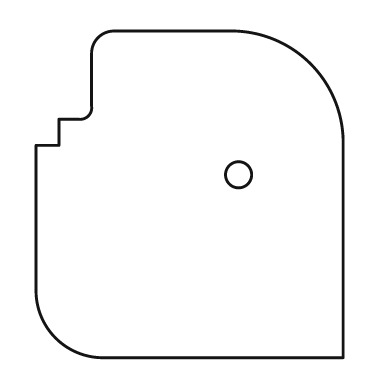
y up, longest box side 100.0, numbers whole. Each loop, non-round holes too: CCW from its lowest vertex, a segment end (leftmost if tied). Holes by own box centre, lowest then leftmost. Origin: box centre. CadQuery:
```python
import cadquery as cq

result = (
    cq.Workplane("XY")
    .moveTo(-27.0, -50.0)
    .lineTo(47.0, -50.0)
    .lineTo(47.0, 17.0)
    .threePointArc((37.0, 40.0), (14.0, 50.0))
    .lineTo(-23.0, 50.0)
    .threePointArc((-28.0, 48.0), (-30.0, 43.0))
    .lineTo(-30.0, 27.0)
    .threePointArc((-31.0, 24.0), (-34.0, 23.0))
    .lineTo(-40.0, 23.0)
    .lineTo(-40.0, 15.0)
    .lineTo(-47.0, 15.0)
    .lineTo(-47.0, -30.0)
    .threePointArc((-41.0, -44.0), (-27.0, -50.0))
    .close()
    .moveTo(15.0, 6.0)
    .circle(4.0)
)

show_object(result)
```